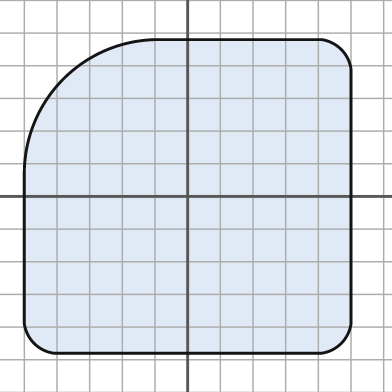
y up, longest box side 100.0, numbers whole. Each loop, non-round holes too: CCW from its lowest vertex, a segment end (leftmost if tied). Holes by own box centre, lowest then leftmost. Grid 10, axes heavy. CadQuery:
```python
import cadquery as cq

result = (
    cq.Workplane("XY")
    .moveTo(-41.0, -48.0)
    .lineTo(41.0, -48.0)
    .threePointArc((47.0, -45.0), (50.0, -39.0))
    .lineTo(50.0, 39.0)
    .threePointArc((47.0, 45.0), (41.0, 48.0))
    .lineTo(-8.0, 48.0)
    .threePointArc((-38.0, 36.0), (-50.0, 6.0))
    .lineTo(-50.0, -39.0)
    .threePointArc((-47.0, -45.0), (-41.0, -48.0))
    .close()
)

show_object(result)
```